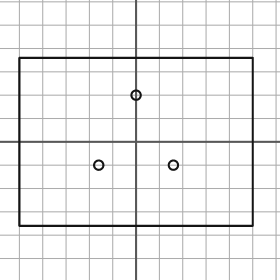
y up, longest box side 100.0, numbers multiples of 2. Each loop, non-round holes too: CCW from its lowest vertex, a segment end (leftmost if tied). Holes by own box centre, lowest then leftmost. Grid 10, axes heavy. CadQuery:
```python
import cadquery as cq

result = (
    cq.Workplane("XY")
    .moveTo(-50.0, -36.0)
    .lineTo(50.0, -36.0)
    .lineTo(50.0, 36.0)
    .lineTo(-50.0, 36.0)
    .close()
    .moveTo(-16.0, -10.0)
    .circle(2.0)
    .moveTo(16.0, -10.0)
    .circle(2.0)
    .moveTo(0.0, 20.0)
    .circle(2.0)
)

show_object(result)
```